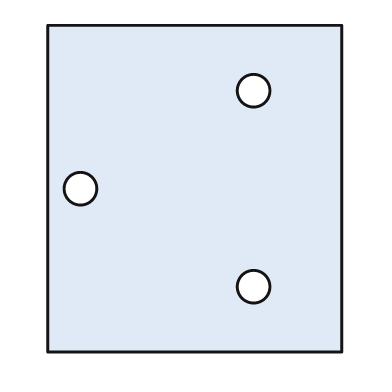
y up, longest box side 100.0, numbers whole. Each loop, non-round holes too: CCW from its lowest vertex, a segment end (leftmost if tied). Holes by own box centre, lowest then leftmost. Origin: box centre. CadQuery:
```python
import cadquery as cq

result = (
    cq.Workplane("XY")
    .moveTo(-45.0, -50.0)
    .lineTo(45.0, -50.0)
    .lineTo(45.0, 50.0)
    .lineTo(-45.0, 50.0)
    .close()
    .moveTo(18.0, -30.0)
    .circle(5.0)
    .moveTo(-35.0, 0.0)
    .circle(5.0)
    .moveTo(18.0, 30.0)
    .circle(5.0)
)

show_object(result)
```